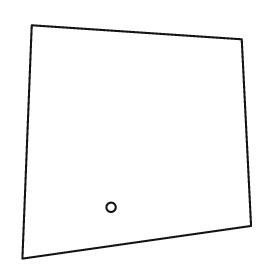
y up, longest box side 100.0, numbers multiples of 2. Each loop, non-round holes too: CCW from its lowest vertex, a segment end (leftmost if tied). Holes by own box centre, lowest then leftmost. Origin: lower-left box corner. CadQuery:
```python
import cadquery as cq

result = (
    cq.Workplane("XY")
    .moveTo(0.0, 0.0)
    .lineTo(98.0, 14.0)
    .lineTo(94.0, 94.0)
    .lineTo(4.0, 100.0)
    .close()
    .moveTo(38.0, 22.0)
    .circle(2.0)
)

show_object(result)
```